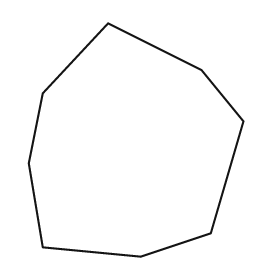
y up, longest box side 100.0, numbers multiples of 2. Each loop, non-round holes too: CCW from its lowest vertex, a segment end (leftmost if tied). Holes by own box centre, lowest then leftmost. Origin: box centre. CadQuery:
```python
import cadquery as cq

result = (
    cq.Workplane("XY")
    .moveTo(2.0, -50.0)
    .lineTo(32.0, -40.0)
    .lineTo(46.0, 8.0)
    .lineTo(28.0, 30.0)
    .lineTo(-12.0, 50.0)
    .lineTo(-40.0, 20.0)
    .lineTo(-46.0, -10.0)
    .lineTo(-40.0, -46.0)
    .close()
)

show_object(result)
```